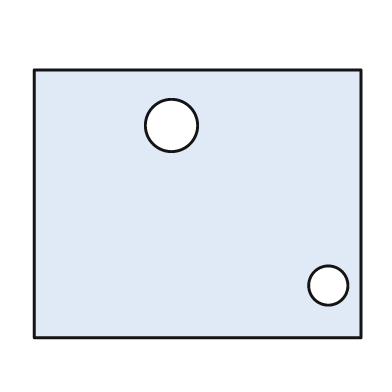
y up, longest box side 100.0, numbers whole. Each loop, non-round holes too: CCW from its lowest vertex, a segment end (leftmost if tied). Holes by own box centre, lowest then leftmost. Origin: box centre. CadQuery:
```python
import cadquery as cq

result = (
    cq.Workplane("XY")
    .moveTo(-50.0, -41.0)
    .lineTo(50.0, -41.0)
    .lineTo(50.0, 41.0)
    .lineTo(-50.0, 41.0)
    .close()
    .moveTo(40.0, -25.0)
    .circle(6.0)
    .moveTo(-8.0, 24.0)
    .circle(8.0)
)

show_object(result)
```